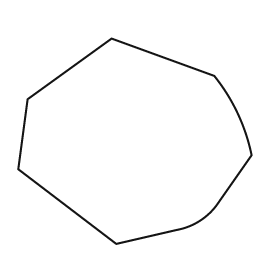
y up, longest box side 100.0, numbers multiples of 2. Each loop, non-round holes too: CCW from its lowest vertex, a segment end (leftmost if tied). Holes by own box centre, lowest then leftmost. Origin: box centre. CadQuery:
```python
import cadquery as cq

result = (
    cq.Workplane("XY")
    .moveTo(-8.0, -44.0)
    .lineTo(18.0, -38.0)
    .threePointArc((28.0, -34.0), (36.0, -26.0))
    .lineTo(50.0, -6.0)
    .threePointArc((44.0, 12.0), (34.0, 28.0))
    .lineTo(-10.0, 44.0)
    .lineTo(-46.0, 18.0)
    .lineTo(-50.0, -12.0)
    .close()
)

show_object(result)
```